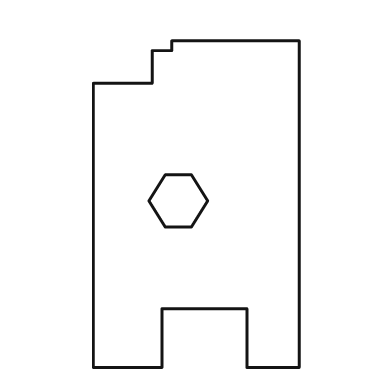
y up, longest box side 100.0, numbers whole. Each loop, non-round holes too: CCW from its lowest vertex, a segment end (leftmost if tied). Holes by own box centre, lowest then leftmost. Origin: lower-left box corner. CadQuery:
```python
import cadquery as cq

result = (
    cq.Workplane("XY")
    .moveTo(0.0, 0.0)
    .lineTo(21.0, 0.0)
    .lineTo(21.0, 18.0)
    .lineTo(47.0, 18.0)
    .lineTo(47.0, 0.0)
    .lineTo(63.0, 0.0)
    .lineTo(63.0, 100.0)
    .lineTo(24.0, 100.0)
    .lineTo(24.0, 97.0)
    .lineTo(18.0, 97.0)
    .lineTo(18.0, 87.0)
    .lineTo(0.0, 87.0)
    .close()
    .moveTo(22.0, 43.0)
    .lineTo(30.0, 43.0)
    .lineTo(35.0, 51.0)
    .lineTo(30.0, 59.0)
    .lineTo(22.0, 59.0)
    .lineTo(17.0, 51.0)
    .close()
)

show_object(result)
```